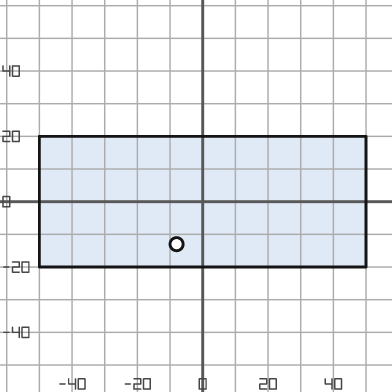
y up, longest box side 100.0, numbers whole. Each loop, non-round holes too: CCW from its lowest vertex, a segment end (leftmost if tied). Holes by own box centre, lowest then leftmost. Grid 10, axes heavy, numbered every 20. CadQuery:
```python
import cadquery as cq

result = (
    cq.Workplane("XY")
    .moveTo(-50.0, -20.0)
    .lineTo(50.0, -20.0)
    .lineTo(50.0, 20.0)
    .lineTo(-50.0, 20.0)
    .close()
    .moveTo(-8.0, -13.0)
    .circle(2.0)
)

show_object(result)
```